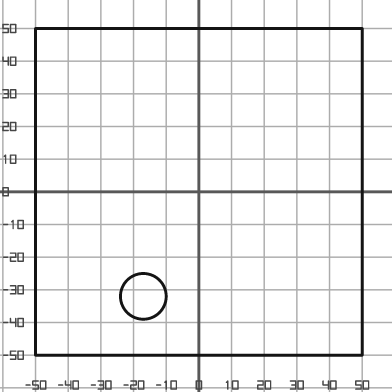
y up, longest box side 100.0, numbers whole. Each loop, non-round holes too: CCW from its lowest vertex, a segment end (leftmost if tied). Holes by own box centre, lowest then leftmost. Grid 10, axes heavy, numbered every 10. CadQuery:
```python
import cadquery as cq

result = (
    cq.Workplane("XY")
    .moveTo(-50.0, -50.0)
    .lineTo(50.0, -50.0)
    .lineTo(50.0, 50.0)
    .lineTo(-50.0, 50.0)
    .close()
    .moveTo(-17.0, -32.0)
    .circle(7.0)
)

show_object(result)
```